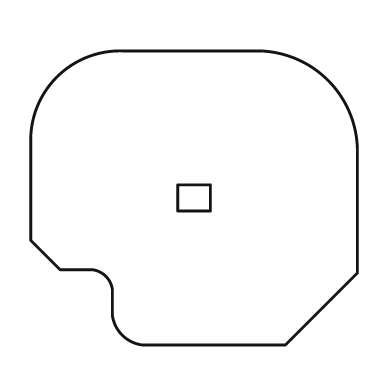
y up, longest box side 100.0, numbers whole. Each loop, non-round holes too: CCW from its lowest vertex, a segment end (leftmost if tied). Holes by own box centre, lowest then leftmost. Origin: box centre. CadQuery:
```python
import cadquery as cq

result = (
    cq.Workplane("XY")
    .moveTo(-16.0, -45.0)
    .lineTo(28.0, -45.0)
    .lineTo(50.0, -23.0)
    .lineTo(50.0, 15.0)
    .threePointArc((41.0, 36.0), (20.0, 45.0))
    .lineTo(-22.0, 45.0)
    .threePointArc((-42.0, 37.0), (-50.0, 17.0))
    .lineTo(-50.0, -13.0)
    .lineTo(-41.0, -22.0)
    .lineTo(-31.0, -22.0)
    .threePointArc((-27.0, -24.0), (-25.0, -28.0))
    .lineTo(-25.0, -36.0)
    .threePointArc((-22.0, -42.0), (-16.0, -45.0))
    .close()
    .moveTo(-5.0, -4.0)
    .lineTo(5.0, -4.0)
    .lineTo(5.0, 4.0)
    .lineTo(-5.0, 4.0)
    .close()
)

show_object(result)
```